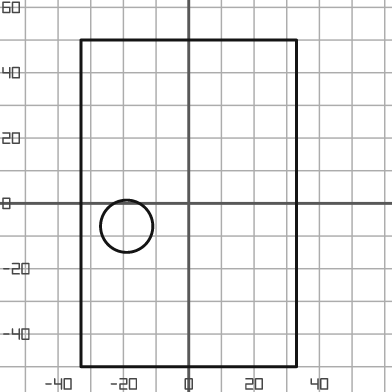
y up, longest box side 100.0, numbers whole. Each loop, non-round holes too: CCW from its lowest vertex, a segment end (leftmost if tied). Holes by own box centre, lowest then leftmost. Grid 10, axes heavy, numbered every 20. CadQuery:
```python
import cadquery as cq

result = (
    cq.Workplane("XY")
    .moveTo(-33.0, -50.0)
    .lineTo(33.0, -50.0)
    .lineTo(33.0, 50.0)
    .lineTo(-33.0, 50.0)
    .close()
    .moveTo(-19.0, -7.0)
    .circle(8.0)
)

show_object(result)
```